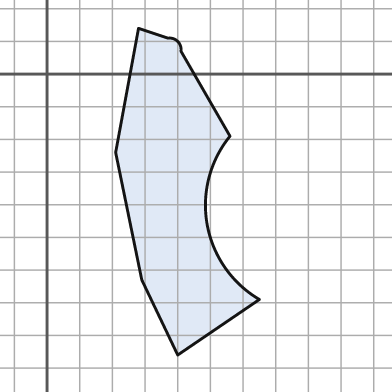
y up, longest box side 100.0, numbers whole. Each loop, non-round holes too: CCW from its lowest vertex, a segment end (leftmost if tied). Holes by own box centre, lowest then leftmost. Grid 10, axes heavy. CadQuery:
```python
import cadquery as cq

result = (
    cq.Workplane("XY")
    .moveTo(40.0, -86.0)
    .lineTo(65.0, -69.0)
    .threePointArc((49.0, -46.0), (56.0, -19.0))
    .lineTo(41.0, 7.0)
    .threePointArc((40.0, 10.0), (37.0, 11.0))
    .lineTo(28.0, 14.0)
    .lineTo(21.0, -24.0)
    .lineTo(29.0, -63.0)
    .close()
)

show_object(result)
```